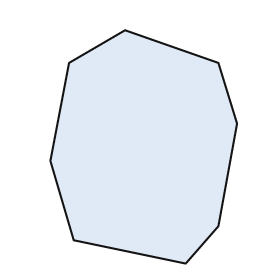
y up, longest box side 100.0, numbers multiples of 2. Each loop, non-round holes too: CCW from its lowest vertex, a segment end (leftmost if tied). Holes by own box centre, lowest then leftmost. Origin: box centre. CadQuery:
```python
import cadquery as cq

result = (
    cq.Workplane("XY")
    .moveTo(18.0, -50.0)
    .lineTo(32.0, -34.0)
    .lineTo(40.0, 10.0)
    .lineTo(32.0, 36.0)
    .lineTo(-8.0, 50.0)
    .lineTo(-32.0, 36.0)
    .lineTo(-40.0, -6.0)
    .lineTo(-30.0, -40.0)
    .close()
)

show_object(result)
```